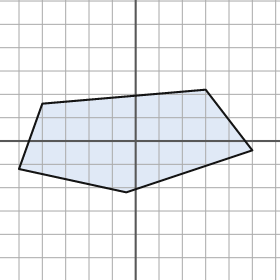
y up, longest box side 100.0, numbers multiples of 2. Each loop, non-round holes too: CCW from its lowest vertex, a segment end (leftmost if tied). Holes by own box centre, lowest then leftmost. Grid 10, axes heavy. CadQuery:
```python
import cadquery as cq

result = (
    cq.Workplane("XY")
    .moveTo(-4.0, -22.0)
    .lineTo(50.0, -4.0)
    .lineTo(30.0, 22.0)
    .lineTo(-40.0, 16.0)
    .lineTo(-50.0, -12.0)
    .close()
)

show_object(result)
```